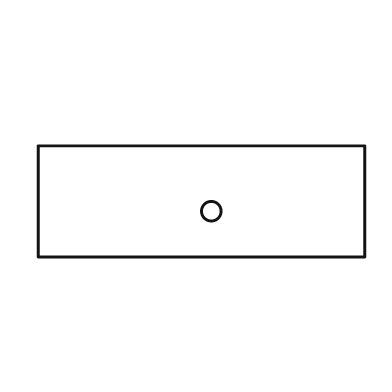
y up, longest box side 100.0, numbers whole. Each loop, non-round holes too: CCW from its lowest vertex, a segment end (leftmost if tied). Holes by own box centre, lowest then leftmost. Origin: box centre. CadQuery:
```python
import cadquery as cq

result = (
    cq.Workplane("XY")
    .moveTo(-50.0, -17.0)
    .lineTo(50.0, -17.0)
    .lineTo(50.0, 17.0)
    .lineTo(-50.0, 17.0)
    .close()
    .moveTo(3.0, -3.0)
    .circle(3.0)
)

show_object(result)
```